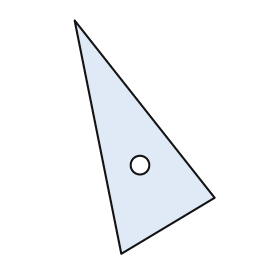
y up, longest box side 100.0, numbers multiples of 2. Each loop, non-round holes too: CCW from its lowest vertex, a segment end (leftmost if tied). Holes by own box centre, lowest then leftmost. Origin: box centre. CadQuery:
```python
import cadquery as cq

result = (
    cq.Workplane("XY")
    .moveTo(-10.0, -50.0)
    .lineTo(30.0, -26.0)
    .lineTo(-30.0, 50.0)
    .close()
    .moveTo(-2.0, -12.0)
    .circle(4.0)
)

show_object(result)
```